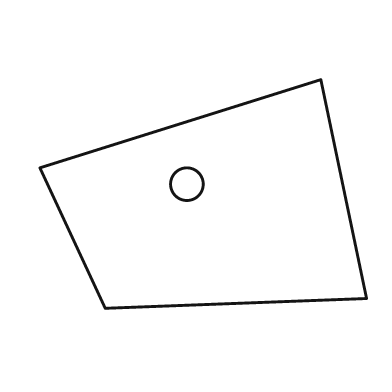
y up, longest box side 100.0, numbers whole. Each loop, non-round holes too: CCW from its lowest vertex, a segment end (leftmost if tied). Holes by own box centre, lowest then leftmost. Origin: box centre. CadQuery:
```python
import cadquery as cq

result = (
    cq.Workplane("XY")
    .moveTo(-30.0, -35.0)
    .lineTo(50.0, -32.0)
    .lineTo(36.0, 35.0)
    .lineTo(-50.0, 8.0)
    .close()
    .moveTo(-5.0, 3.0)
    .circle(5.0)
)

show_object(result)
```